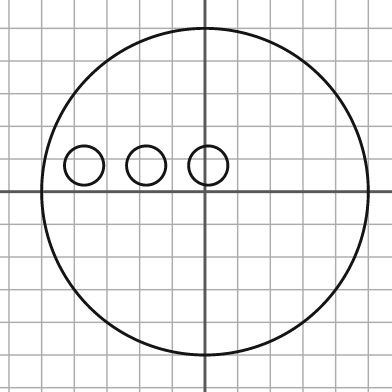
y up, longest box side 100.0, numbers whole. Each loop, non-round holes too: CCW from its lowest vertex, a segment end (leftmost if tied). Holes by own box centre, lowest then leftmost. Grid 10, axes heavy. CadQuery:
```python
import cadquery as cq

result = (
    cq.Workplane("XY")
    .moveTo(0.0, 0.0)
    .circle(50.0)
    .moveTo(-37.0, 8.0)
    .circle(6.0)
    .moveTo(-18.0, 8.0)
    .circle(6.0)
    .moveTo(1.0, 8.0)
    .circle(6.0)
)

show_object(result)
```